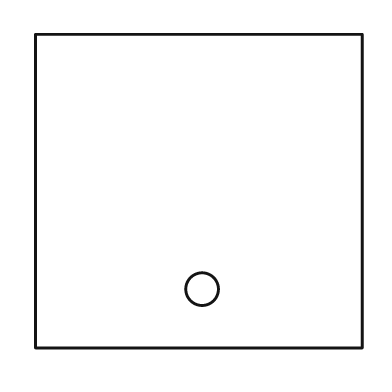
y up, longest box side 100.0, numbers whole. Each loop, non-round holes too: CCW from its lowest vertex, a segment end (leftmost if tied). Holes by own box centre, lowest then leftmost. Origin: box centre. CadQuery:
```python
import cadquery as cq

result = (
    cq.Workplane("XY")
    .moveTo(-50.0, -48.0)
    .lineTo(50.0, -48.0)
    .lineTo(50.0, 48.0)
    .lineTo(-50.0, 48.0)
    .close()
    .moveTo(1.0, -30.0)
    .circle(5.0)
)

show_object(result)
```